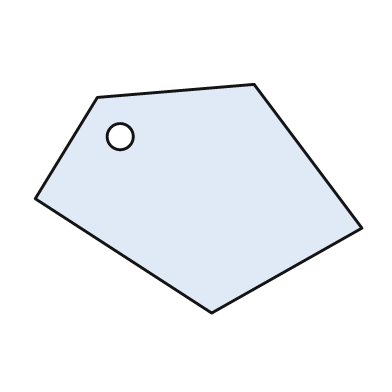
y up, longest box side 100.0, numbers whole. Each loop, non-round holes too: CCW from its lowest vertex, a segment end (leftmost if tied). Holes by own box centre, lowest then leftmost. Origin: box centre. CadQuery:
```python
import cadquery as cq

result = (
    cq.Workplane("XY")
    .moveTo(4.0, -35.0)
    .lineTo(50.0, -9.0)
    .lineTo(17.0, 35.0)
    .lineTo(-31.0, 31.0)
    .lineTo(-50.0, 0.0)
    .close()
    .moveTo(-24.0, 19.0)
    .circle(4.0)
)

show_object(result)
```